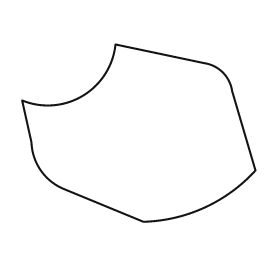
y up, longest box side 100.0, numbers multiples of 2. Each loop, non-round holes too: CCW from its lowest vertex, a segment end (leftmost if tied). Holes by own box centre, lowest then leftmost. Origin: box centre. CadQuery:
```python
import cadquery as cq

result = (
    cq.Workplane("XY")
    .moveTo(2.0, -38.0)
    .threePointArc((28.0, -32.0), (50.0, -16.0))
    .lineTo(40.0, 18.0)
    .threePointArc((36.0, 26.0), (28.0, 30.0))
    .lineTo(-10.0, 38.0)
    .threePointArc((-24.0, 16.0), (-50.0, 14.0))
    .lineTo(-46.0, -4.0)
    .threePointArc((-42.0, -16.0), (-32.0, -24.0))
    .close()
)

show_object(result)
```